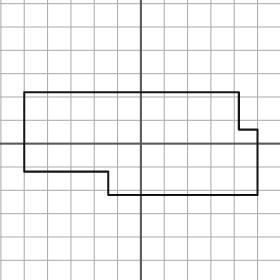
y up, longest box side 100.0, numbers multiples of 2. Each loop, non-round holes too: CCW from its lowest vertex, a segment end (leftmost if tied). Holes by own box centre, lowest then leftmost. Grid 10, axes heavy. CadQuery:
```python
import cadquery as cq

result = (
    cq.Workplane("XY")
    .moveTo(-14.0, -22.0)
    .lineTo(50.0, -22.0)
    .lineTo(50.0, 6.0)
    .lineTo(42.0, 6.0)
    .lineTo(42.0, 22.0)
    .lineTo(-50.0, 22.0)
    .lineTo(-50.0, -12.0)
    .lineTo(-14.0, -12.0)
    .close()
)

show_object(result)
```